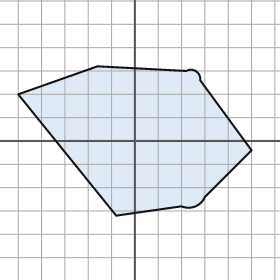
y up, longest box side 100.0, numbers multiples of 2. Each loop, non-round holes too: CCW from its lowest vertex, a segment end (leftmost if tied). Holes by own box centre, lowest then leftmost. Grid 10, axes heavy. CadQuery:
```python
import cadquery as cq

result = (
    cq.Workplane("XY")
    .moveTo(-8.0, -32.0)
    .lineTo(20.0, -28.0)
    .threePointArc((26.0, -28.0), (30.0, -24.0))
    .lineTo(50.0, -4.0)
    .lineTo(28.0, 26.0)
    .threePointArc((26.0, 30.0), (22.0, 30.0))
    .lineTo(-16.0, 32.0)
    .lineTo(-50.0, 20.0)
    .close()
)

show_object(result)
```